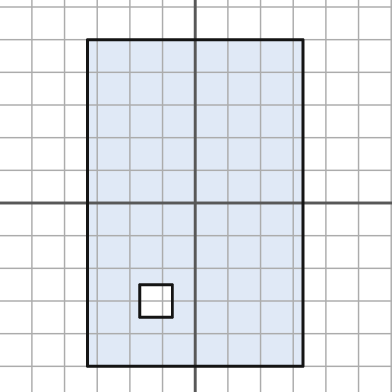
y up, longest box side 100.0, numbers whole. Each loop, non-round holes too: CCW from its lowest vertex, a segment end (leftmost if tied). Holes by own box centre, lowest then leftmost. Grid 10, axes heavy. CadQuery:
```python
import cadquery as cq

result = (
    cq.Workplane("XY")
    .moveTo(-33.0, -50.0)
    .lineTo(33.0, -50.0)
    .lineTo(33.0, 50.0)
    .lineTo(-33.0, 50.0)
    .close()
    .moveTo(-17.0, -35.0)
    .lineTo(-7.0, -35.0)
    .lineTo(-7.0, -25.0)
    .lineTo(-17.0, -25.0)
    .close()
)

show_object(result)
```